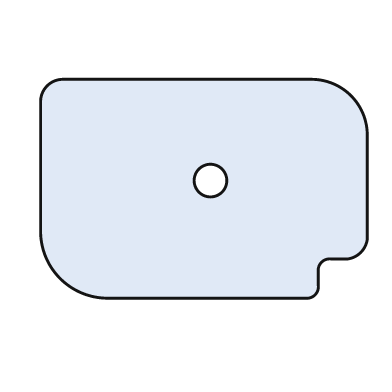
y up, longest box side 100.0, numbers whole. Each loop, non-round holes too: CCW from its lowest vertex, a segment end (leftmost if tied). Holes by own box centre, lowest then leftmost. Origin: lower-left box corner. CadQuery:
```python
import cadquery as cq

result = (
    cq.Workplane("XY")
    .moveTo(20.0, 0.0)
    .lineTo(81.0, 0.0)
    .threePointArc((84.0, 1.0), (85.0, 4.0))
    .lineTo(85.0, 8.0)
    .threePointArc((86.0, 11.0), (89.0, 12.0))
    .lineTo(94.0, 12.0)
    .threePointArc((98.0, 14.0), (100.0, 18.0))
    .lineTo(100.0, 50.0)
    .threePointArc((95.0, 62.0), (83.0, 67.0))
    .lineTo(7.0, 67.0)
    .threePointArc((2.0, 65.0), (0.0, 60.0))
    .lineTo(0.0, 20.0)
    .threePointArc((6.0, 6.0), (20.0, 0.0))
    .close()
    .moveTo(52.0, 36.0)
    .circle(5.0)
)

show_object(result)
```